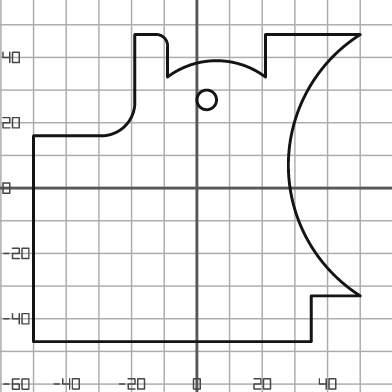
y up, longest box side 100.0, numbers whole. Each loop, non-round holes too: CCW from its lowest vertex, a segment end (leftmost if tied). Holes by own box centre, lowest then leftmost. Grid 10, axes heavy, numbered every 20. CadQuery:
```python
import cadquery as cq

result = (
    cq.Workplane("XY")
    .moveTo(-50.0, -47.0)
    .lineTo(35.0, -47.0)
    .lineTo(35.0, -33.0)
    .lineTo(50.0, -33.0)
    .threePointArc((28.0, 7.0), (50.0, 47.0))
    .lineTo(21.0, 47.0)
    .lineTo(21.0, 34.0)
    .threePointArc((6.0, 39.0), (-9.0, 34.0))
    .lineTo(-9.0, 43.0)
    .threePointArc((-10.0, 46.0), (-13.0, 47.0))
    .lineTo(-19.0, 47.0)
    .lineTo(-19.0, 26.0)
    .threePointArc((-22.0, 19.0), (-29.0, 16.0))
    .lineTo(-50.0, 16.0)
    .close()
    .moveTo(3.0, 27.0)
    .circle(3.0)
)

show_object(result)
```